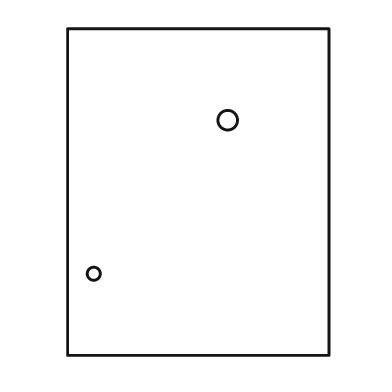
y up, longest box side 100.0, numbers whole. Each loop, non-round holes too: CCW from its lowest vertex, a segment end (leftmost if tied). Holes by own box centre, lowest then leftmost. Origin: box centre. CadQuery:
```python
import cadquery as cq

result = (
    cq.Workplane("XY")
    .moveTo(-40.0, -50.0)
    .lineTo(40.0, -50.0)
    .lineTo(40.0, 50.0)
    .lineTo(-40.0, 50.0)
    .close()
    .moveTo(-32.0, -25.0)
    .circle(2.0)
    .moveTo(9.0, 22.0)
    .circle(3.0)
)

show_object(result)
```